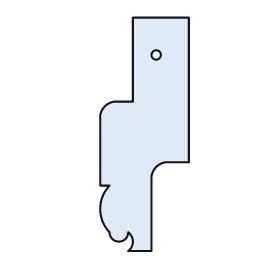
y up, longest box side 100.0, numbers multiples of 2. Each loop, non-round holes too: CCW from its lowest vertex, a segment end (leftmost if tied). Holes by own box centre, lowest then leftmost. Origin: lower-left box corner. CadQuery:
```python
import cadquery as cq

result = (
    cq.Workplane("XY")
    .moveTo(12.0, 0.0)
    .lineTo(22.0, 0.0)
    .lineTo(22.0, 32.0)
    .threePointArc((24.0, 36.0), (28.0, 38.0))
    .lineTo(38.0, 38.0)
    .lineTo(38.0, 100.0)
    .lineTo(14.0, 100.0)
    .lineTo(14.0, 64.0)
    .lineTo(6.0, 64.0)
    .threePointArc((2.0, 62.0), (0.0, 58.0))
    .lineTo(0.0, 28.0)
    .lineTo(4.0, 28.0)
    .threePointArc((0.0, 18.0), (4.0, 8.0))
    .threePointArc((8.0, 4.0), (12.0, 8.0))
    .threePointArc((14.0, 4.0), (12.0, 0.0))
    .close()
    .moveTo(24.0, 84.0)
    .circle(2.0)
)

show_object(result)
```